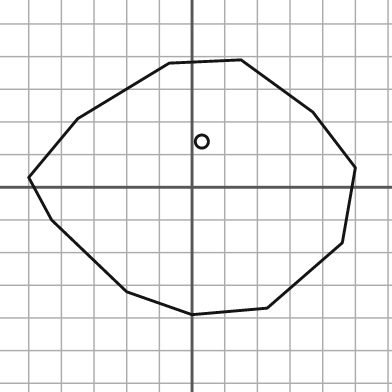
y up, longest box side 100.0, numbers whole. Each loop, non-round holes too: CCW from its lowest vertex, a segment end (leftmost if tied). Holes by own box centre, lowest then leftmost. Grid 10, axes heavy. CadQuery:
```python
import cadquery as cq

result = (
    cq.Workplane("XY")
    .moveTo(0.0, -39.0)
    .lineTo(23.0, -37.0)
    .lineTo(46.0, -17.0)
    .lineTo(50.0, 6.0)
    .lineTo(37.0, 23.0)
    .lineTo(15.0, 39.0)
    .lineTo(-7.0, 38.0)
    .lineTo(-35.0, 21.0)
    .lineTo(-50.0, 3.0)
    .lineTo(-43.0, -10.0)
    .lineTo(-20.0, -32.0)
    .close()
    .moveTo(3.0, 14.0)
    .circle(2.0)
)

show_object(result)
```